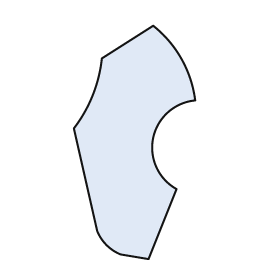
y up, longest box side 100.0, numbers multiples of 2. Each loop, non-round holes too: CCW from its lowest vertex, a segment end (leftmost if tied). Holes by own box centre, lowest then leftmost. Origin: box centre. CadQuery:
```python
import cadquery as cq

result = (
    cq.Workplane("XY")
    .moveTo(6.0, -50.0)
    .lineTo(18.0, -20.0)
    .threePointArc((8.0, 2.0), (26.0, 18.0))
    .threePointArc((20.0, 36.0), (8.0, 50.0))
    .lineTo(-14.0, 36.0)
    .threePointArc((-18.0, 20.0), (-26.0, 6.0))
    .lineTo(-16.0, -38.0)
    .threePointArc((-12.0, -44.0), (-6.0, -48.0))
    .close()
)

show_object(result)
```